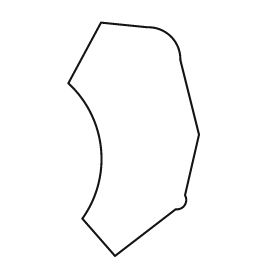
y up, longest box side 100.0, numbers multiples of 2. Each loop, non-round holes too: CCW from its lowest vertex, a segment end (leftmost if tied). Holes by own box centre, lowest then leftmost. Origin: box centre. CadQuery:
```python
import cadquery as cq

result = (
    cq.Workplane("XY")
    .moveTo(-8.0, -50.0)
    .lineTo(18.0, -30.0)
    .threePointArc((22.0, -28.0), (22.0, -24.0))
    .lineTo(28.0, 2.0)
    .lineTo(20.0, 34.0)
    .threePointArc((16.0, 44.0), (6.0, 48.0))
    .lineTo(-14.0, 50.0)
    .lineTo(-28.0, 24.0)
    .threePointArc((-14.0, -4.0), (-22.0, -34.0))
    .close()
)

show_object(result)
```